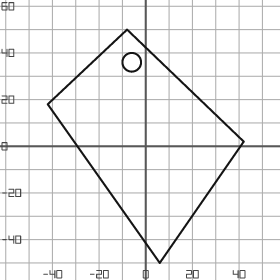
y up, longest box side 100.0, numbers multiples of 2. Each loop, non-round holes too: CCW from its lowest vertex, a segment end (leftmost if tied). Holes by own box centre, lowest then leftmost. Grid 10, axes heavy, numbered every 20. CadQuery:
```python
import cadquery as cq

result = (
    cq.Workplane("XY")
    .moveTo(6.0, -50.0)
    .lineTo(42.0, 2.0)
    .lineTo(-8.0, 50.0)
    .lineTo(-42.0, 18.0)
    .close()
    .moveTo(-6.0, 36.0)
    .circle(4.0)
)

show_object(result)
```